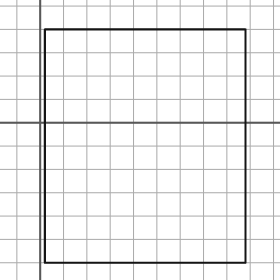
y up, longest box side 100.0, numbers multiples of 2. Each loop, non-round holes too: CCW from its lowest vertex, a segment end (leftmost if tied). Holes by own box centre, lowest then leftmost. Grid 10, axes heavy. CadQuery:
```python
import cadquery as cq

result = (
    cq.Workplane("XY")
    .moveTo(2.0, -60.0)
    .lineTo(88.0, -60.0)
    .lineTo(88.0, 40.0)
    .lineTo(2.0, 40.0)
    .close()
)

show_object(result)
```